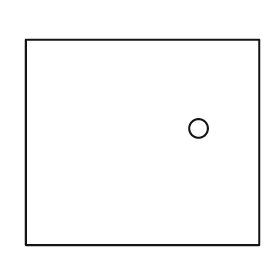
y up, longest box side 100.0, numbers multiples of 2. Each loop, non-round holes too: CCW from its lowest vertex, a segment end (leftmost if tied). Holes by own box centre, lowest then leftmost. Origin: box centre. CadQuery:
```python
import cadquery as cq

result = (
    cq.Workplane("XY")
    .moveTo(-50.0, -44.0)
    .lineTo(50.0, -44.0)
    .lineTo(50.0, 44.0)
    .lineTo(-50.0, 44.0)
    .close()
    .moveTo(24.0, 6.0)
    .circle(4.0)
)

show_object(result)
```